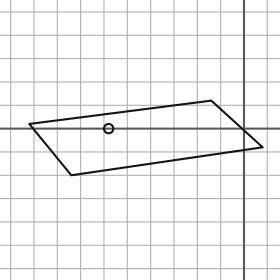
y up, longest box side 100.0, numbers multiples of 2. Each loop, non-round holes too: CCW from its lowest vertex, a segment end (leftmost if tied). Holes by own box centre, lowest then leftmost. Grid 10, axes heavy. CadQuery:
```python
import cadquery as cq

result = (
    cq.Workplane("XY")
    .moveTo(-74.0, -20.0)
    .lineTo(8.0, -8.0)
    .lineTo(-14.0, 12.0)
    .lineTo(-92.0, 2.0)
    .close()
    .moveTo(-58.0, 0.0)
    .circle(2.0)
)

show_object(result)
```